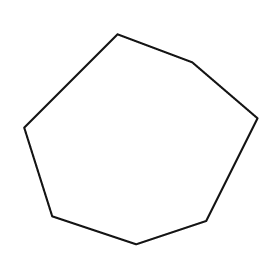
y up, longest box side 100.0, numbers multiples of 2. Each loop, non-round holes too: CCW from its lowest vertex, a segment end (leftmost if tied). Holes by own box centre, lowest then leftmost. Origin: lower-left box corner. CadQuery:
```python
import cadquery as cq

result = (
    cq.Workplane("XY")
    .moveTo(48.0, 0.0)
    .lineTo(78.0, 10.0)
    .lineTo(100.0, 54.0)
    .lineTo(72.0, 78.0)
    .lineTo(40.0, 90.0)
    .lineTo(0.0, 50.0)
    .lineTo(12.0, 12.0)
    .close()
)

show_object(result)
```